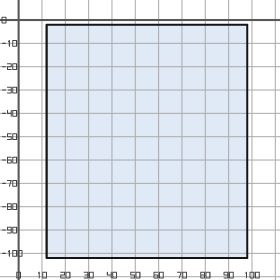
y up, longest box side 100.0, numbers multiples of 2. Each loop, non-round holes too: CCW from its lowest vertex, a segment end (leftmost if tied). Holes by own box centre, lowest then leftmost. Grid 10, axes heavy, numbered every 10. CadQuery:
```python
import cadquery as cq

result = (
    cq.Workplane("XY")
    .moveTo(12.0, -102.0)
    .lineTo(98.0, -102.0)
    .lineTo(98.0, -2.0)
    .lineTo(12.0, -2.0)
    .close()
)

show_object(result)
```